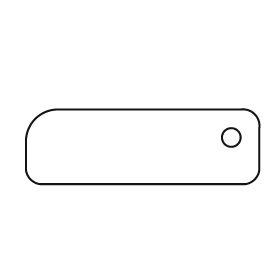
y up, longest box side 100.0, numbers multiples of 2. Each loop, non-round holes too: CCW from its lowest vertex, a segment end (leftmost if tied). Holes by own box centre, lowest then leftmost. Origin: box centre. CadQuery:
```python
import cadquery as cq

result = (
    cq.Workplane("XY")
    .moveTo(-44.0, -16.0)
    .lineTo(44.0, -16.0)
    .threePointArc((48.0, -14.0), (50.0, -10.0))
    .lineTo(50.0, 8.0)
    .threePointArc((48.0, 14.0), (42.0, 16.0))
    .lineTo(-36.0, 16.0)
    .threePointArc((-46.0, 12.0), (-50.0, 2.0))
    .lineTo(-50.0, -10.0)
    .threePointArc((-48.0, -14.0), (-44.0, -16.0))
    .close()
    .moveTo(38.0, 4.0)
    .circle(4.0)
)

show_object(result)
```